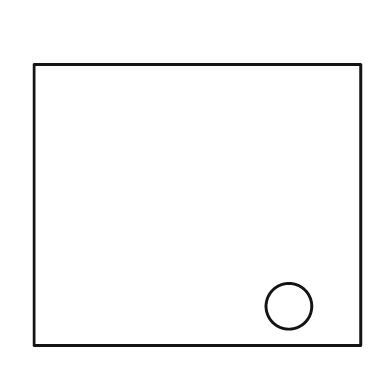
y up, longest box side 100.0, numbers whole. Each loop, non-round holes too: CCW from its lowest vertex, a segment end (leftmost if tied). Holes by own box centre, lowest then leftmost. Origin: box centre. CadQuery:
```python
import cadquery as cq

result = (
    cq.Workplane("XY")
    .moveTo(-50.0, -43.0)
    .lineTo(50.0, -43.0)
    .lineTo(50.0, 43.0)
    .lineTo(-50.0, 43.0)
    .close()
    .moveTo(28.0, -31.0)
    .circle(7.0)
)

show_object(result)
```